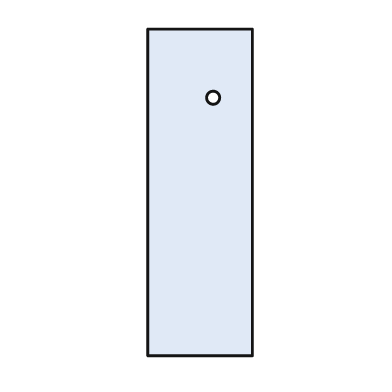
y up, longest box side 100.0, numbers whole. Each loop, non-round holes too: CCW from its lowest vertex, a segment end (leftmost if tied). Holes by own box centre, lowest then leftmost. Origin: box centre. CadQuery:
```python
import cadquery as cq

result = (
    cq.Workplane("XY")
    .moveTo(-16.0, -50.0)
    .lineTo(16.0, -50.0)
    .lineTo(16.0, 50.0)
    .lineTo(-16.0, 50.0)
    .close()
    .moveTo(4.0, 29.0)
    .circle(2.0)
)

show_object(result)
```